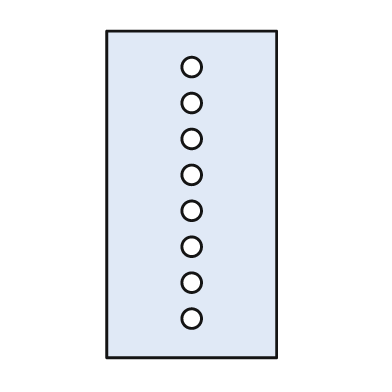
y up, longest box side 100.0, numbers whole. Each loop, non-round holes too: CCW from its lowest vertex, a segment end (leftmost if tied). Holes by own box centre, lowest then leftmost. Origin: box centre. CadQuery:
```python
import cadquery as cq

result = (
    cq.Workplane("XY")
    .moveTo(-26.0, -50.0)
    .lineTo(26.0, -50.0)
    .lineTo(26.0, 50.0)
    .lineTo(-26.0, 50.0)
    .close()
    .moveTo(0.0, -38.0)
    .circle(3.0)
    .moveTo(0.0, -27.0)
    .circle(3.0)
    .moveTo(0.0, -16.0)
    .circle(3.0)
    .moveTo(0.0, -5.0)
    .circle(3.0)
    .moveTo(0.0, 6.0)
    .circle(3.0)
    .moveTo(0.0, 17.0)
    .circle(3.0)
    .moveTo(0.0, 28.0)
    .circle(3.0)
    .moveTo(0.0, 39.0)
    .circle(3.0)
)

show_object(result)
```